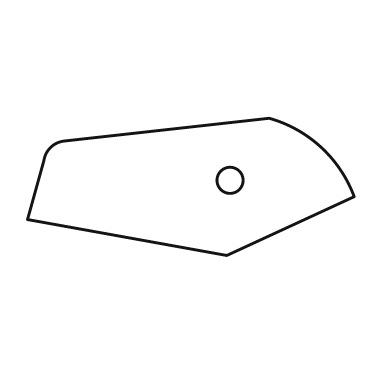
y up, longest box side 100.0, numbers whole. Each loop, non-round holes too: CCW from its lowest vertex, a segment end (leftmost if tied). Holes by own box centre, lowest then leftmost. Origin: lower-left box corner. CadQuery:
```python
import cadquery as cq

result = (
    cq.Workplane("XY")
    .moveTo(61.0, 0.0)
    .lineTo(100.0, 18.0)
    .threePointArc((90.0, 33.0), (74.0, 42.0))
    .lineTo(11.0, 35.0)
    .threePointArc((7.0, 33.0), (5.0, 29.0))
    .lineTo(0.0, 11.0)
    .close()
    .moveTo(62.0, 23.0)
    .circle(4.0)
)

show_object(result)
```